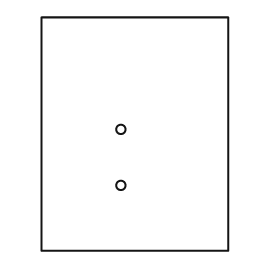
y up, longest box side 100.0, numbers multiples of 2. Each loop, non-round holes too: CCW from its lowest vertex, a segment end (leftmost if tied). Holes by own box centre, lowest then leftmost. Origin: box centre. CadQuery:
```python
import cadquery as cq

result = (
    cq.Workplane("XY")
    .moveTo(-40.0, -50.0)
    .lineTo(40.0, -50.0)
    .lineTo(40.0, 50.0)
    .lineTo(-40.0, 50.0)
    .close()
    .moveTo(-6.0, -22.0)
    .circle(2.0)
    .moveTo(-6.0, 2.0)
    .circle(2.0)
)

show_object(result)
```